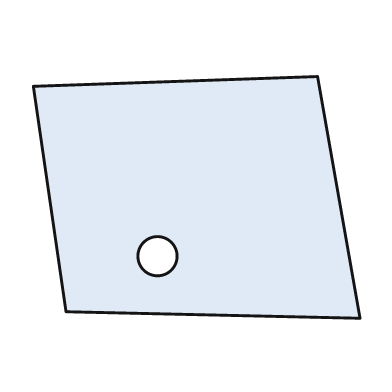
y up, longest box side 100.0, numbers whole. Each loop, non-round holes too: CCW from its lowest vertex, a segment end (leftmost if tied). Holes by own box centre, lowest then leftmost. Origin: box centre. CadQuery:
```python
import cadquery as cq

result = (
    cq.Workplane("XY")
    .moveTo(50.0, -37.0)
    .lineTo(37.0, 37.0)
    .lineTo(-50.0, 34.0)
    .lineTo(-40.0, -35.0)
    .close()
    .moveTo(-12.0, -18.0)
    .circle(6.0)
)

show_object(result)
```